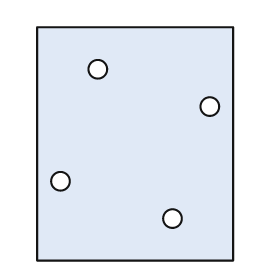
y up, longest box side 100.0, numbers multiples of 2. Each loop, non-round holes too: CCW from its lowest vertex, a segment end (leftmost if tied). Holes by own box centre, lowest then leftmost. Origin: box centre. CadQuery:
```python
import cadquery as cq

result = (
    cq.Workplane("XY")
    .moveTo(-42.0, -50.0)
    .lineTo(42.0, -50.0)
    .lineTo(42.0, 50.0)
    .lineTo(-42.0, 50.0)
    .close()
    .moveTo(16.0, -32.0)
    .circle(4.0)
    .moveTo(-32.0, -16.0)
    .circle(4.0)
    .moveTo(32.0, 16.0)
    .circle(4.0)
    .moveTo(-16.0, 32.0)
    .circle(4.0)
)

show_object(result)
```